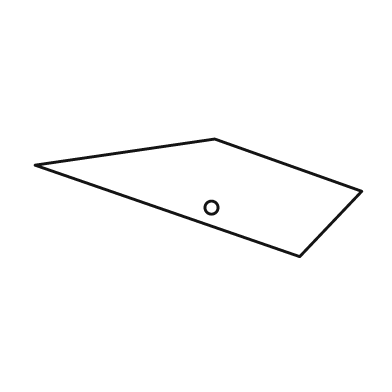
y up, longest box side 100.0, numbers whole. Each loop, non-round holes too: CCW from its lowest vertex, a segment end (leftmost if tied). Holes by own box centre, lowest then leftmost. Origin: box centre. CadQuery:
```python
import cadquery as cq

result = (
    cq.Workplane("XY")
    .moveTo(31.0, -18.0)
    .lineTo(50.0, 2.0)
    .lineTo(5.0, 18.0)
    .lineTo(-50.0, 10.0)
    .close()
    .moveTo(4.0, -3.0)
    .circle(2.0)
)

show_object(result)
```